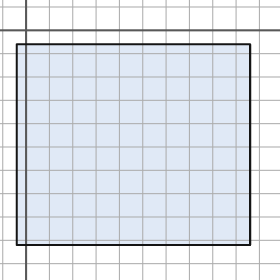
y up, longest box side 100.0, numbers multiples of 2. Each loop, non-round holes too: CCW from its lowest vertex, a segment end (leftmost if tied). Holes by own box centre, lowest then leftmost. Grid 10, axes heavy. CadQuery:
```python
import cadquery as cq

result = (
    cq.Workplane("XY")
    .moveTo(-4.0, -92.0)
    .lineTo(96.0, -92.0)
    .lineTo(96.0, -6.0)
    .lineTo(-4.0, -6.0)
    .close()
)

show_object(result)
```